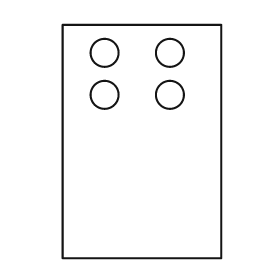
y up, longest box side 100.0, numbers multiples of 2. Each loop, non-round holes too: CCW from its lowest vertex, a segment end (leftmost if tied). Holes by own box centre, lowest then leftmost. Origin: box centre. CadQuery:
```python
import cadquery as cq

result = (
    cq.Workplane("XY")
    .moveTo(-34.0, -50.0)
    .lineTo(34.0, -50.0)
    .lineTo(34.0, 50.0)
    .lineTo(-34.0, 50.0)
    .close()
    .moveTo(-16.0, 20.0)
    .circle(6.0)
    .moveTo(12.0, 20.0)
    .circle(6.0)
    .moveTo(-16.0, 38.0)
    .circle(6.0)
    .moveTo(12.0, 38.0)
    .circle(6.0)
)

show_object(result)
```